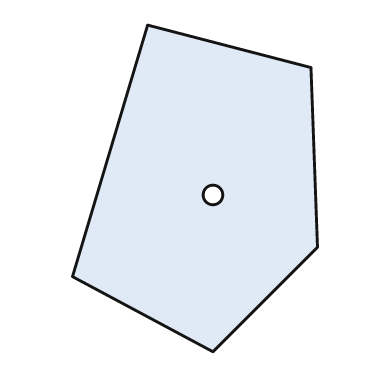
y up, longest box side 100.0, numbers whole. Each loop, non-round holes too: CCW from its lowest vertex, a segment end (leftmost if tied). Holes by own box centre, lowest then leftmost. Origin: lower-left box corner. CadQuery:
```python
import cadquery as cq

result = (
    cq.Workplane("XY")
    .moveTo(43.0, 0.0)
    .lineTo(75.0, 32.0)
    .lineTo(73.0, 87.0)
    .lineTo(23.0, 100.0)
    .lineTo(0.0, 23.0)
    .close()
    .moveTo(43.0, 48.0)
    .circle(3.0)
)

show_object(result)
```